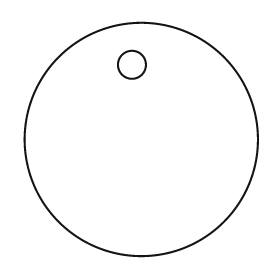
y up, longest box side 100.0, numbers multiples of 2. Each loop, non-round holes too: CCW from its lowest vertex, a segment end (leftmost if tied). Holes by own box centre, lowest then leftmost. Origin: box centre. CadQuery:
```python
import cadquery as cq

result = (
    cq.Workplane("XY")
    .moveTo(0.0, 0.0)
    .circle(50.0)
    .moveTo(-4.0, 32.0)
    .circle(6.0)
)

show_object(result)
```